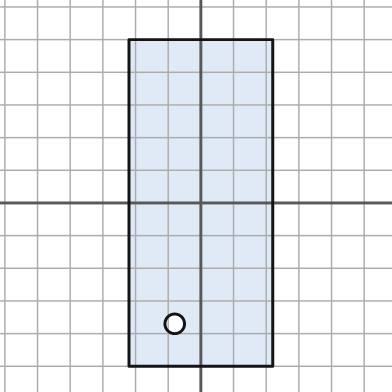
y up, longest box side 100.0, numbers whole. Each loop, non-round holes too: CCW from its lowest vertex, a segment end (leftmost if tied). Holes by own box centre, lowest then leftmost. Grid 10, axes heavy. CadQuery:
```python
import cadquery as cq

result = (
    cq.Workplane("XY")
    .moveTo(-22.0, -50.0)
    .lineTo(22.0, -50.0)
    .lineTo(22.0, 50.0)
    .lineTo(-22.0, 50.0)
    .close()
    .moveTo(-8.0, -37.0)
    .circle(3.0)
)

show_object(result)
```